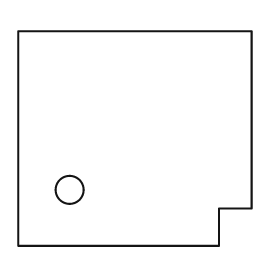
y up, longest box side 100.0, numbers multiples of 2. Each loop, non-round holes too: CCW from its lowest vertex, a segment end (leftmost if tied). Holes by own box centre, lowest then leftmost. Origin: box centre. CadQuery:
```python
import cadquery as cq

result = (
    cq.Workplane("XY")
    .moveTo(-50.0, -46.0)
    .lineTo(36.0, -46.0)
    .lineTo(36.0, -30.0)
    .lineTo(50.0, -30.0)
    .lineTo(50.0, 46.0)
    .lineTo(-50.0, 46.0)
    .close()
    .moveTo(-28.0, -22.0)
    .circle(6.0)
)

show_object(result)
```